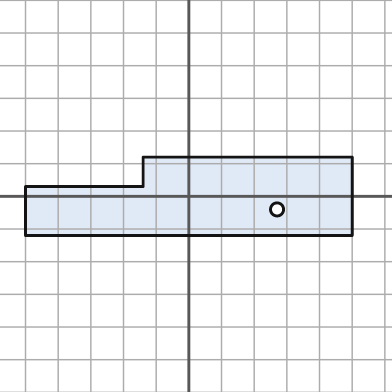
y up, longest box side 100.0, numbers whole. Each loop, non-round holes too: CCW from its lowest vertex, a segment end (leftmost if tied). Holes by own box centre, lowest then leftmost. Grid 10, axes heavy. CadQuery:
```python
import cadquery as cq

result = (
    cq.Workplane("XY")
    .moveTo(-50.0, -12.0)
    .lineTo(50.0, -12.0)
    .lineTo(50.0, 12.0)
    .lineTo(-14.0, 12.0)
    .lineTo(-14.0, 3.0)
    .lineTo(-50.0, 3.0)
    .close()
    .moveTo(27.0, -4.0)
    .circle(2.0)
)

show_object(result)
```